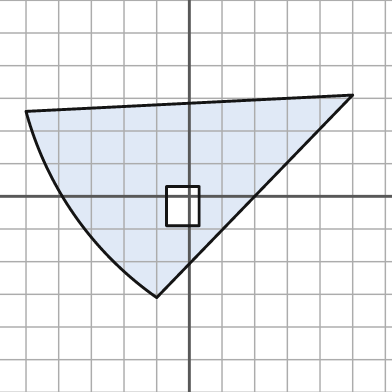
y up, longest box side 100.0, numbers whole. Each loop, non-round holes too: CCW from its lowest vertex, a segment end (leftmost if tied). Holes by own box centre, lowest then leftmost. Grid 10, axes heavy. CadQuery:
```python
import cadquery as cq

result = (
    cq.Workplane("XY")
    .moveTo(-10.0, -31.0)
    .lineTo(50.0, 31.0)
    .lineTo(-50.0, 26.0)
    .threePointArc((-35.0, -6.0), (-10.0, -31.0))
    .close()
    .moveTo(-7.0, -9.0)
    .lineTo(3.0, -9.0)
    .lineTo(3.0, 3.0)
    .lineTo(-7.0, 3.0)
    .close()
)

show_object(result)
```